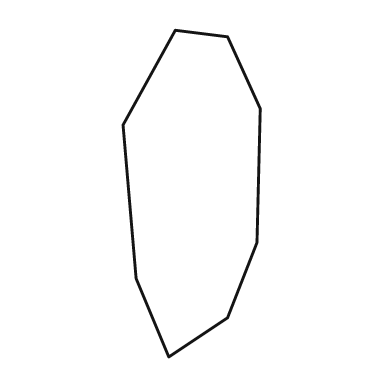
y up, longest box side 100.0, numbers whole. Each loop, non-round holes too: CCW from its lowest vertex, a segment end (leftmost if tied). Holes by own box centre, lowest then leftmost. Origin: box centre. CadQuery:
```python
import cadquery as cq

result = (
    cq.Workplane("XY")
    .moveTo(-7.0, -50.0)
    .lineTo(11.0, -38.0)
    .lineTo(20.0, -15.0)
    .lineTo(21.0, 26.0)
    .lineTo(11.0, 48.0)
    .lineTo(-5.0, 50.0)
    .lineTo(-21.0, 21.0)
    .lineTo(-17.0, -26.0)
    .close()
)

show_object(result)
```